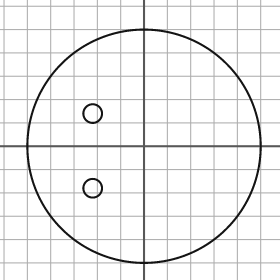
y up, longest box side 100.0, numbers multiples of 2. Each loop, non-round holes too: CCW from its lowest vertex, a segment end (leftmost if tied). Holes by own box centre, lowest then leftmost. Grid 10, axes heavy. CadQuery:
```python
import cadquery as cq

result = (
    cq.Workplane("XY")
    .moveTo(0.0, 0.0)
    .circle(50.0)
    .moveTo(-22.0, -18.0)
    .circle(4.0)
    .moveTo(-22.0, 14.0)
    .circle(4.0)
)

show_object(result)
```